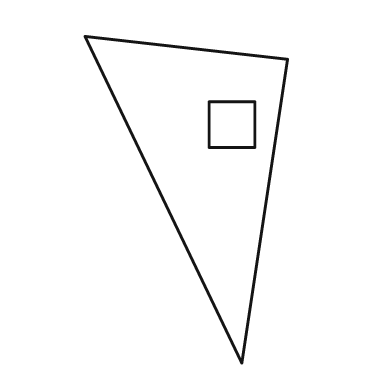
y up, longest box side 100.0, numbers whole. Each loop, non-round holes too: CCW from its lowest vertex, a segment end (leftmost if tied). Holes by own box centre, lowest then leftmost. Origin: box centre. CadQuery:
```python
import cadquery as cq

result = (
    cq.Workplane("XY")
    .moveTo(17.0, -50.0)
    .lineTo(31.0, 43.0)
    .lineTo(-31.0, 50.0)
    .close()
    .moveTo(7.0, 16.0)
    .lineTo(21.0, 16.0)
    .lineTo(21.0, 30.0)
    .lineTo(7.0, 30.0)
    .close()
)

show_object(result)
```